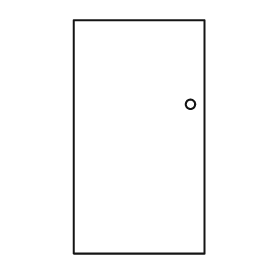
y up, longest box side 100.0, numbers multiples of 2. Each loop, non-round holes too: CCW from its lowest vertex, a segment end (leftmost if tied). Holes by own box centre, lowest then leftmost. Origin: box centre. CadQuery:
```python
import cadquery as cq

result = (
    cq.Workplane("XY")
    .moveTo(-28.0, -50.0)
    .lineTo(28.0, -50.0)
    .lineTo(28.0, 50.0)
    .lineTo(-28.0, 50.0)
    .close()
    .moveTo(22.0, 14.0)
    .circle(2.0)
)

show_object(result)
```